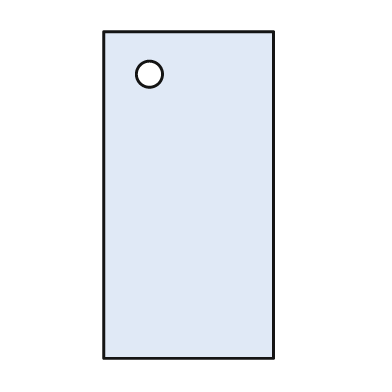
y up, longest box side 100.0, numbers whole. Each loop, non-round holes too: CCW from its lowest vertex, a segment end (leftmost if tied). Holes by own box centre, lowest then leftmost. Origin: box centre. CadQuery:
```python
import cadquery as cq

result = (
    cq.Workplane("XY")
    .moveTo(-26.0, -50.0)
    .lineTo(26.0, -50.0)
    .lineTo(26.0, 50.0)
    .lineTo(-26.0, 50.0)
    .close()
    .moveTo(-12.0, 37.0)
    .circle(4.0)
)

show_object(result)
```